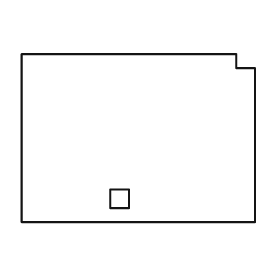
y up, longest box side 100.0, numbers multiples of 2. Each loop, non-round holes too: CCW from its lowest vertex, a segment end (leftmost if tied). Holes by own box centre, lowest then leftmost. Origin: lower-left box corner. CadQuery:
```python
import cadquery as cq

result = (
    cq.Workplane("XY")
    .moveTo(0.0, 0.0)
    .lineTo(100.0, 0.0)
    .lineTo(100.0, 66.0)
    .lineTo(92.0, 66.0)
    .lineTo(92.0, 72.0)
    .lineTo(0.0, 72.0)
    .close()
    .moveTo(38.0, 6.0)
    .lineTo(46.0, 6.0)
    .lineTo(46.0, 14.0)
    .lineTo(38.0, 14.0)
    .close()
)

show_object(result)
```